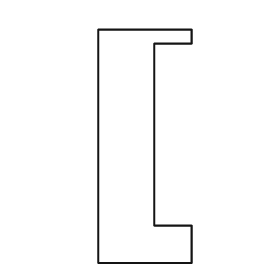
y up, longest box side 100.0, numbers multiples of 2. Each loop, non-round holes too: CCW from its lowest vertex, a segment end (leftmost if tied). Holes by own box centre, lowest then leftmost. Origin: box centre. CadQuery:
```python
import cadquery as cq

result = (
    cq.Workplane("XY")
    .moveTo(-20.0, -50.0)
    .lineTo(20.0, -50.0)
    .lineTo(20.0, -34.0)
    .lineTo(4.0, -34.0)
    .lineTo(4.0, 44.0)
    .lineTo(20.0, 44.0)
    .lineTo(20.0, 50.0)
    .lineTo(-20.0, 50.0)
    .close()
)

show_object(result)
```